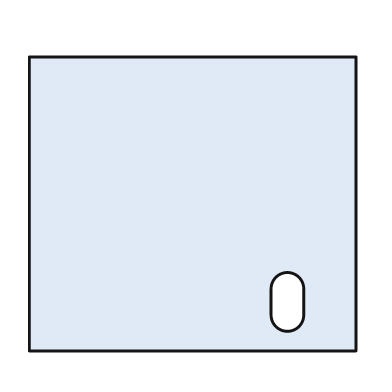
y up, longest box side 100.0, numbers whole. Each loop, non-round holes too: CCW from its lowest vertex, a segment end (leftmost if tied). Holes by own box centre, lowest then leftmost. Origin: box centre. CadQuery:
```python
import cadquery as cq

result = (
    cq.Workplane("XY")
    .moveTo(-50.0, -45.0)
    .lineTo(50.0, -45.0)
    .lineTo(50.0, 45.0)
    .lineTo(-50.0, 45.0)
    .close()
    .moveTo(24.0, -34.0)
    .threePointArc((29.0, -39.0), (34.0, -34.0))
    .lineTo(34.0, -26.0)
    .threePointArc((29.0, -21.0), (24.0, -26.0))
    .close()
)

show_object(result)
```